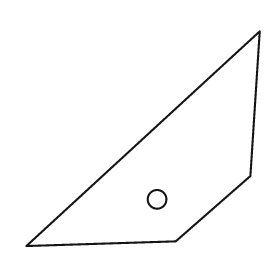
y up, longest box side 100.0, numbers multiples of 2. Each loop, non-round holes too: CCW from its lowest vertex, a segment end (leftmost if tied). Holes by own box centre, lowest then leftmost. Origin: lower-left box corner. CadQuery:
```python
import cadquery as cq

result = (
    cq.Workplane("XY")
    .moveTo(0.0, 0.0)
    .lineTo(64.0, 2.0)
    .lineTo(96.0, 30.0)
    .lineTo(100.0, 92.0)
    .close()
    .moveTo(56.0, 20.0)
    .circle(4.0)
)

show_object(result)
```